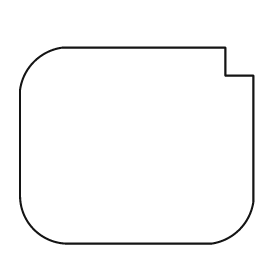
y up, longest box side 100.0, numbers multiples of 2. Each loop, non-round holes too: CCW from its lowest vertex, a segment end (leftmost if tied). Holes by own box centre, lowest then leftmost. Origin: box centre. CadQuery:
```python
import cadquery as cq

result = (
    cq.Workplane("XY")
    .moveTo(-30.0, -42.0)
    .lineTo(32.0, -42.0)
    .threePointArc((44.0, -36.0), (50.0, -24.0))
    .lineTo(50.0, 30.0)
    .lineTo(38.0, 30.0)
    .lineTo(38.0, 42.0)
    .lineTo(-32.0, 42.0)
    .threePointArc((-44.0, 36.0), (-50.0, 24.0))
    .lineTo(-50.0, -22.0)
    .threePointArc((-44.0, -36.0), (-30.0, -42.0))
    .close()
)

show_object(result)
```